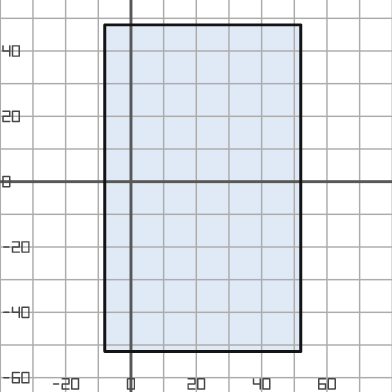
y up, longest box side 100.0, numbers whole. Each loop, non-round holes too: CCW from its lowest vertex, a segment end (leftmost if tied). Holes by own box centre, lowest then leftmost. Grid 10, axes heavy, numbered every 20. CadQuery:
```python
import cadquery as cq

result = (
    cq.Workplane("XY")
    .moveTo(-8.0, -52.0)
    .lineTo(52.0, -52.0)
    .lineTo(52.0, 48.0)
    .lineTo(-8.0, 48.0)
    .close()
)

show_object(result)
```